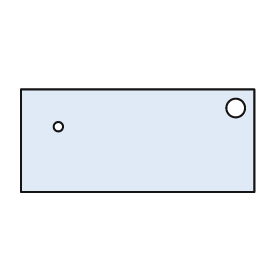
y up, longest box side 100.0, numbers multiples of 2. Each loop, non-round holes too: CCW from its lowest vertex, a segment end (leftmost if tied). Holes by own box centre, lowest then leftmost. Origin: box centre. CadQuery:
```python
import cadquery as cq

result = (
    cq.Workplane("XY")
    .moveTo(-50.0, -22.0)
    .lineTo(50.0, -22.0)
    .lineTo(50.0, 22.0)
    .lineTo(-50.0, 22.0)
    .close()
    .moveTo(-34.0, 6.0)
    .circle(2.0)
    .moveTo(42.0, 14.0)
    .circle(4.0)
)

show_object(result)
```